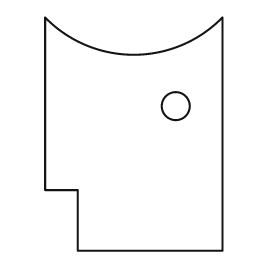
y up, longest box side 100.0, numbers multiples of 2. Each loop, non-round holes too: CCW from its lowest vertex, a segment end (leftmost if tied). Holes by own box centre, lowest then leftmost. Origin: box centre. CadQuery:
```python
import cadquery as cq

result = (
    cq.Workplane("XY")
    .moveTo(-24.0, -50.0)
    .lineTo(38.0, -50.0)
    .lineTo(38.0, 50.0)
    .threePointArc((0.0, 34.0), (-38.0, 50.0))
    .lineTo(-38.0, -24.0)
    .lineTo(-24.0, -24.0)
    .close()
    .moveTo(18.0, 12.0)
    .circle(6.0)
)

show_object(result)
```